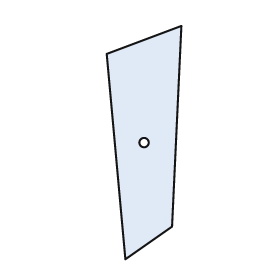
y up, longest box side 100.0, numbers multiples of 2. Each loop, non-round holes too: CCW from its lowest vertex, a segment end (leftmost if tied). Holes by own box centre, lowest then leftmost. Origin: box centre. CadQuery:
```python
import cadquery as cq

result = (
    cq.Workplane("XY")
    .moveTo(-8.0, -50.0)
    .lineTo(12.0, -36.0)
    .lineTo(16.0, 50.0)
    .lineTo(-16.0, 38.0)
    .close()
    .moveTo(0.0, 0.0)
    .circle(2.0)
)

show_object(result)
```